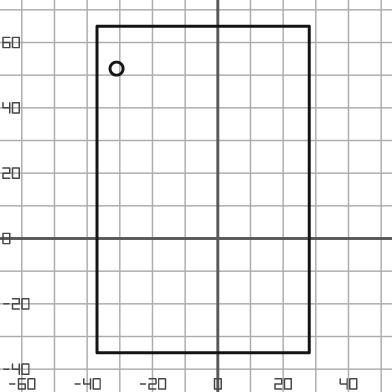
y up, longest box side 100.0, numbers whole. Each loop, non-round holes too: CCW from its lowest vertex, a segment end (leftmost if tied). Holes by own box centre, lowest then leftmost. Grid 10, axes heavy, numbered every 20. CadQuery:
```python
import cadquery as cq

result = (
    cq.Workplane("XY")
    .moveTo(-37.0, -35.0)
    .lineTo(28.0, -35.0)
    .lineTo(28.0, 65.0)
    .lineTo(-37.0, 65.0)
    .close()
    .moveTo(-31.0, 52.0)
    .circle(2.0)
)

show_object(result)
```